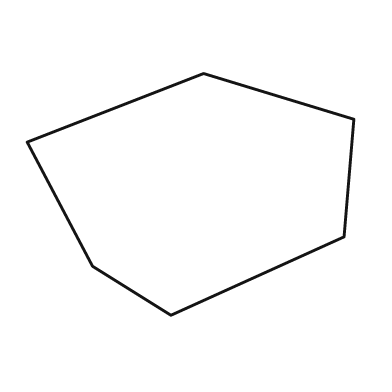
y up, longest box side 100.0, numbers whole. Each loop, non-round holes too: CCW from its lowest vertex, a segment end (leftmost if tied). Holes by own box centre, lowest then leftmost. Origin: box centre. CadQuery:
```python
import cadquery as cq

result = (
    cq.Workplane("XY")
    .moveTo(-6.0, -37.0)
    .lineTo(47.0, -13.0)
    .lineTo(50.0, 23.0)
    .lineTo(4.0, 37.0)
    .lineTo(-50.0, 16.0)
    .lineTo(-30.0, -22.0)
    .close()
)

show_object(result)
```